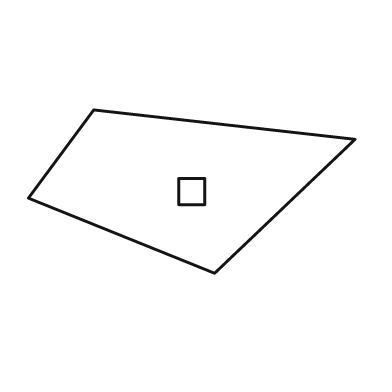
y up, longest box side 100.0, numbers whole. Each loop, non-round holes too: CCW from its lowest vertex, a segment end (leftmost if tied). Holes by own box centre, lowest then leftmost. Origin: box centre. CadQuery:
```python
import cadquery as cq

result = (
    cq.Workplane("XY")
    .moveTo(7.0, -25.0)
    .lineTo(50.0, 16.0)
    .lineTo(-30.0, 25.0)
    .lineTo(-50.0, -2.0)
    .close()
    .moveTo(-4.0, -4.0)
    .lineTo(4.0, -4.0)
    .lineTo(4.0, 4.0)
    .lineTo(-4.0, 4.0)
    .close()
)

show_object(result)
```